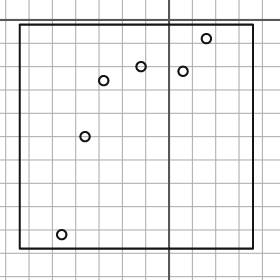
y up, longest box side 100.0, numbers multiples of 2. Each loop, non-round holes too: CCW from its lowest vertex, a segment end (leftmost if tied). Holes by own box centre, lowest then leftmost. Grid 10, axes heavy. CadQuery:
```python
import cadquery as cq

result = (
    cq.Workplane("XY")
    .moveTo(-64.0, -98.0)
    .lineTo(36.0, -98.0)
    .lineTo(36.0, -2.0)
    .lineTo(-64.0, -2.0)
    .close()
    .moveTo(-46.0, -92.0)
    .circle(2.0)
    .moveTo(-36.0, -50.0)
    .circle(2.0)
    .moveTo(-28.0, -26.0)
    .circle(2.0)
    .moveTo(6.0, -22.0)
    .circle(2.0)
    .moveTo(-12.0, -20.0)
    .circle(2.0)
    .moveTo(16.0, -8.0)
    .circle(2.0)
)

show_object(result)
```